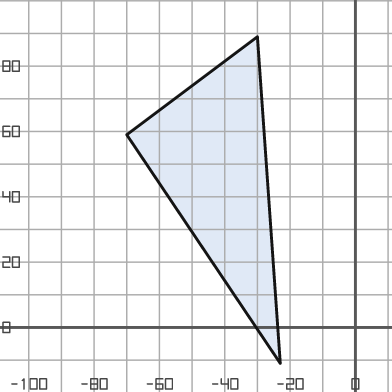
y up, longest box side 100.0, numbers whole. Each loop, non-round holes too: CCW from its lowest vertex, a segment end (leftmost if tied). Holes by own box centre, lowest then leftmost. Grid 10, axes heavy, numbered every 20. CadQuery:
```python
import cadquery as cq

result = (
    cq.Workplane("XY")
    .moveTo(-23.0, -11.0)
    .lineTo(-30.0, 89.0)
    .lineTo(-70.0, 59.0)
    .close()
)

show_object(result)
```